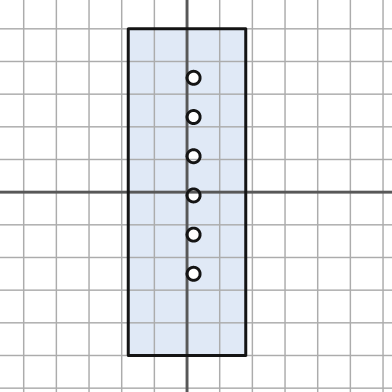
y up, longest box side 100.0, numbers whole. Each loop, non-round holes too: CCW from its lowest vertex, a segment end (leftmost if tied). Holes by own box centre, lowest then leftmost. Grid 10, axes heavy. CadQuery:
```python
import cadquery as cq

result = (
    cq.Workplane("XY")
    .moveTo(-18.0, -50.0)
    .lineTo(18.0, -50.0)
    .lineTo(18.0, 50.0)
    .lineTo(-18.0, 50.0)
    .close()
    .moveTo(2.0, -25.0)
    .circle(2.0)
    .moveTo(2.0, -13.0)
    .circle(2.0)
    .moveTo(2.0, -1.0)
    .circle(2.0)
    .moveTo(2.0, 11.0)
    .circle(2.0)
    .moveTo(2.0, 23.0)
    .circle(2.0)
    .moveTo(2.0, 35.0)
    .circle(2.0)
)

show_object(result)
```